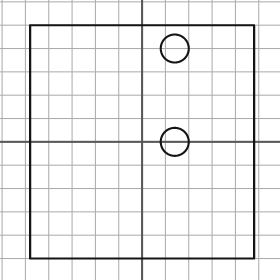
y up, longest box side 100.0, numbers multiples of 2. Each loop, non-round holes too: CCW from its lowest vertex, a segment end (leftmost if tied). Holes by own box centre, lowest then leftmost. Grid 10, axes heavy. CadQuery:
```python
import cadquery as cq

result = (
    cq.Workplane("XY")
    .moveTo(-48.0, -50.0)
    .lineTo(48.0, -50.0)
    .lineTo(48.0, 50.0)
    .lineTo(-48.0, 50.0)
    .close()
    .moveTo(14.0, 0.0)
    .circle(6.0)
    .moveTo(14.0, 40.0)
    .circle(6.0)
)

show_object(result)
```